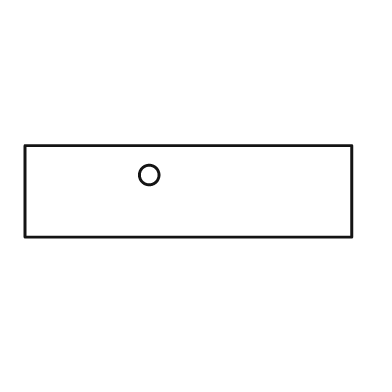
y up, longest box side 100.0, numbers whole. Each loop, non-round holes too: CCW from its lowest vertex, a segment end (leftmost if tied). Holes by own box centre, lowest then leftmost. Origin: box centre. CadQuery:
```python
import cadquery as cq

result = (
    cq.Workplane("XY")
    .moveTo(-50.0, -14.0)
    .lineTo(50.0, -14.0)
    .lineTo(50.0, 14.0)
    .lineTo(-50.0, 14.0)
    .close()
    .moveTo(-12.0, 5.0)
    .circle(3.0)
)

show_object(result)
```